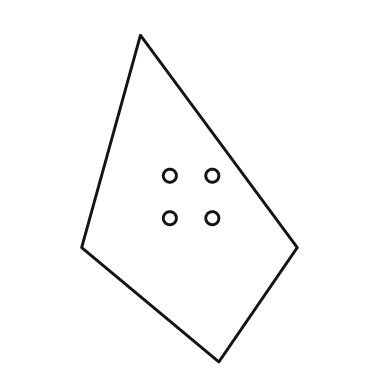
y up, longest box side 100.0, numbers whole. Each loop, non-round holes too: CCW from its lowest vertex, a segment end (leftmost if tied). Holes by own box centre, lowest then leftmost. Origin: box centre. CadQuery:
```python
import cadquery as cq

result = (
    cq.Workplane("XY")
    .moveTo(9.0, -50.0)
    .lineTo(33.0, -15.0)
    .lineTo(-15.0, 50.0)
    .lineTo(-33.0, -15.0)
    .close()
    .moveTo(-6.0, -6.0)
    .circle(2.0)
    .moveTo(7.0, -6.0)
    .circle(2.0)
    .moveTo(-6.0, 7.0)
    .circle(2.0)
    .moveTo(7.0, 7.0)
    .circle(2.0)
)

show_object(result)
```